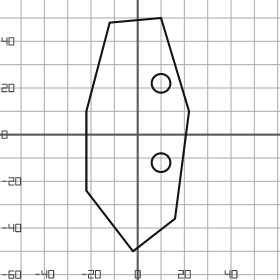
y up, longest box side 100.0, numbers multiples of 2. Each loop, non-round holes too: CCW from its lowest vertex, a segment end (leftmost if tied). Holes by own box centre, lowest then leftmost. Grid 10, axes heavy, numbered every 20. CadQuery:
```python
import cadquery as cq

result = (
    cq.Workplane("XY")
    .moveTo(-2.0, -50.0)
    .lineTo(16.0, -36.0)
    .lineTo(22.0, 10.0)
    .lineTo(10.0, 50.0)
    .lineTo(-12.0, 48.0)
    .lineTo(-22.0, 10.0)
    .lineTo(-22.0, -24.0)
    .close()
    .moveTo(10.0, -12.0)
    .circle(4.0)
    .moveTo(10.0, 22.0)
    .circle(4.0)
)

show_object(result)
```